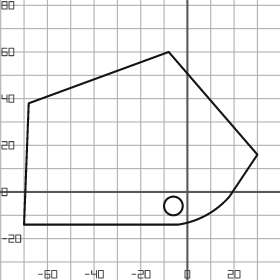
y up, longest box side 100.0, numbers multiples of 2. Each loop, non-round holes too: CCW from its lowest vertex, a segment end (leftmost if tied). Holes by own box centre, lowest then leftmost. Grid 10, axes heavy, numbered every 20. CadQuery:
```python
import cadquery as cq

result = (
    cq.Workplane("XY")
    .moveTo(-70.0, -14.0)
    .lineTo(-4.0, -14.0)
    .threePointArc((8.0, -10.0), (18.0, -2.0))
    .lineTo(30.0, 16.0)
    .lineTo(-8.0, 60.0)
    .lineTo(-68.0, 38.0)
    .close()
    .moveTo(-6.0, -6.0)
    .circle(4.0)
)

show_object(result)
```